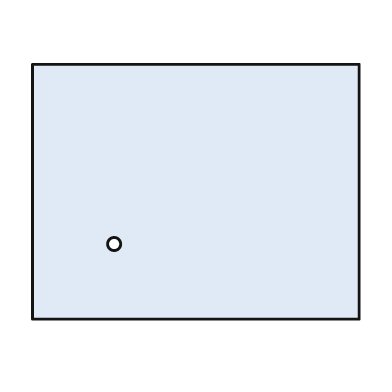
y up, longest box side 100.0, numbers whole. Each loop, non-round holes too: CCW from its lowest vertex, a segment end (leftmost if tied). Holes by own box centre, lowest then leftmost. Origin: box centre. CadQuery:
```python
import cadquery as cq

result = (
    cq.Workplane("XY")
    .moveTo(-50.0, -39.0)
    .lineTo(50.0, -39.0)
    .lineTo(50.0, 39.0)
    .lineTo(-50.0, 39.0)
    .close()
    .moveTo(-25.0, -16.0)
    .circle(2.0)
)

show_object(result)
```